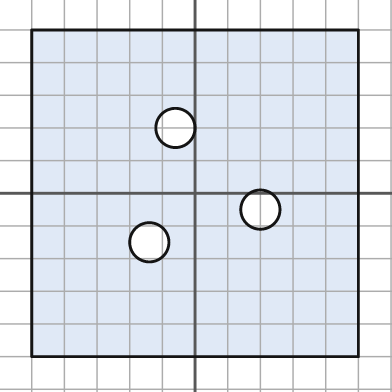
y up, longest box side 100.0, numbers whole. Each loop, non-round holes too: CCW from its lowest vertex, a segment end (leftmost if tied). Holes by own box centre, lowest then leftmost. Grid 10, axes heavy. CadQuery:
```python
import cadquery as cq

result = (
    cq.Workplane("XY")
    .moveTo(-50.0, -50.0)
    .lineTo(50.0, -50.0)
    .lineTo(50.0, 50.0)
    .lineTo(-50.0, 50.0)
    .close()
    .moveTo(-14.0, -15.0)
    .circle(6.0)
    .moveTo(20.0, -5.0)
    .circle(6.0)
    .moveTo(-6.0, 20.0)
    .circle(6.0)
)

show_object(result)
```